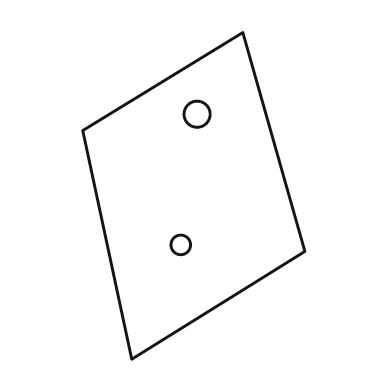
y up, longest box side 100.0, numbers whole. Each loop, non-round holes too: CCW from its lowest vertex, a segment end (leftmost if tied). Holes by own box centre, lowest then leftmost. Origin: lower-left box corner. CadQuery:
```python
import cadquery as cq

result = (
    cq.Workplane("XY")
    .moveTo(15.0, 0.0)
    .lineTo(68.0, 33.0)
    .lineTo(49.0, 100.0)
    .lineTo(0.0, 70.0)
    .close()
    .moveTo(30.0, 35.0)
    .circle(3.0)
    .moveTo(35.0, 75.0)
    .circle(4.0)
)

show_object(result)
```